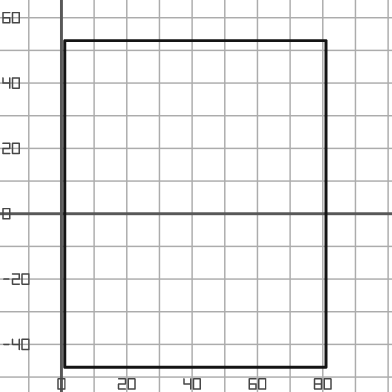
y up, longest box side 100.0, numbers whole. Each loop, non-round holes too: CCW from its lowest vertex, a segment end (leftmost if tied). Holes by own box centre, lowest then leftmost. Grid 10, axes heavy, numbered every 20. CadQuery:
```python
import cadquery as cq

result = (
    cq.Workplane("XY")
    .moveTo(1.0, -47.0)
    .lineTo(81.0, -47.0)
    .lineTo(81.0, 53.0)
    .lineTo(1.0, 53.0)
    .close()
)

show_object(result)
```